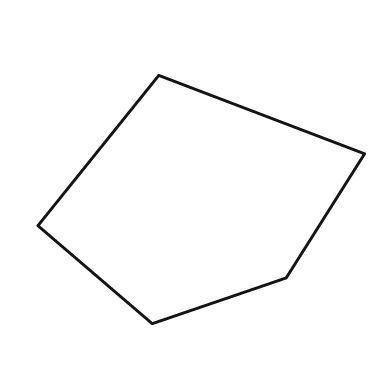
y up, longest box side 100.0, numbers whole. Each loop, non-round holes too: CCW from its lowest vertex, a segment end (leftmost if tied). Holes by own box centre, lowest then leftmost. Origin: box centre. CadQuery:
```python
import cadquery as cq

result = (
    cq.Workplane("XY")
    .moveTo(-15.0, -38.0)
    .lineTo(26.0, -24.0)
    .lineTo(50.0, 14.0)
    .lineTo(-13.0, 38.0)
    .lineTo(-50.0, -8.0)
    .close()
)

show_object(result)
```